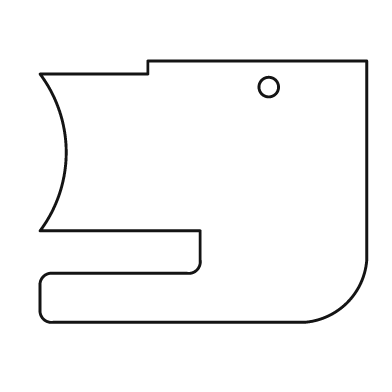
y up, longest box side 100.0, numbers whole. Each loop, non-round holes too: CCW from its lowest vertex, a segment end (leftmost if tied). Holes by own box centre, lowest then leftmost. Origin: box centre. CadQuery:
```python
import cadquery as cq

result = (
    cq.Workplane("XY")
    .moveTo(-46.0, -40.0)
    .lineTo(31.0, -40.0)
    .threePointArc((44.0, -34.0), (50.0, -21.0))
    .lineTo(50.0, 40.0)
    .lineTo(-17.0, 40.0)
    .lineTo(-17.0, 36.0)
    .lineTo(-50.0, 36.0)
    .threePointArc((-42.0, 12.0), (-50.0, -12.0))
    .lineTo(-1.0, -12.0)
    .lineTo(-1.0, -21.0)
    .threePointArc((-2.0, -24.0), (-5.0, -25.0))
    .lineTo(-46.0, -25.0)
    .threePointArc((-49.0, -26.0), (-50.0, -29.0))
    .lineTo(-50.0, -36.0)
    .threePointArc((-49.0, -39.0), (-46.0, -40.0))
    .close()
    .moveTo(20.0, 32.0)
    .circle(3.0)
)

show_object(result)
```